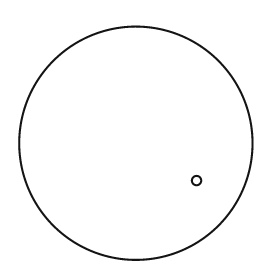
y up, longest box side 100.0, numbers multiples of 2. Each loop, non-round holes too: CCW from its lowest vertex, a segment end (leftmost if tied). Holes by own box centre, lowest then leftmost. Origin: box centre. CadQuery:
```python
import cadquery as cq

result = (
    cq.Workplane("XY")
    .moveTo(0.0, 0.0)
    .circle(50.0)
    .moveTo(26.0, -16.0)
    .circle(2.0)
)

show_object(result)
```